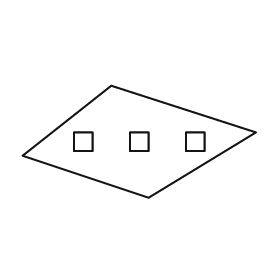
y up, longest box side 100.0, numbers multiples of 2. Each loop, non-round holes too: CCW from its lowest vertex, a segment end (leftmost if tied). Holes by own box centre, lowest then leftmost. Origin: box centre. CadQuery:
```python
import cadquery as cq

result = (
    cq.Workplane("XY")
    .moveTo(4.0, -24.0)
    .lineTo(50.0, 4.0)
    .lineTo(-12.0, 24.0)
    .lineTo(-50.0, -6.0)
    .close()
    .moveTo(-28.0, -4.0)
    .lineTo(-20.0, -4.0)
    .lineTo(-20.0, 4.0)
    .lineTo(-28.0, 4.0)
    .close()
    .moveTo(-4.0, -4.0)
    .lineTo(4.0, -4.0)
    .lineTo(4.0, 4.0)
    .lineTo(-4.0, 4.0)
    .close()
    .moveTo(20.0, -4.0)
    .lineTo(28.0, -4.0)
    .lineTo(28.0, 4.0)
    .lineTo(20.0, 4.0)
    .close()
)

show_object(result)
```